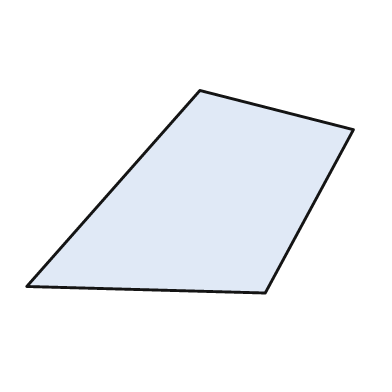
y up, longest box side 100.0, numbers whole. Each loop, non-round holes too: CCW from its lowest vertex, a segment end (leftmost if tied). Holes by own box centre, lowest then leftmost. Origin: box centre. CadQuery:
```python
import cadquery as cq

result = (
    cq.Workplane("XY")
    .moveTo(23.0, -31.0)
    .lineTo(50.0, 19.0)
    .lineTo(3.0, 31.0)
    .lineTo(-50.0, -29.0)
    .close()
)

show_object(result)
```